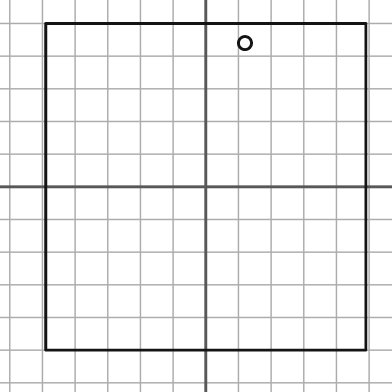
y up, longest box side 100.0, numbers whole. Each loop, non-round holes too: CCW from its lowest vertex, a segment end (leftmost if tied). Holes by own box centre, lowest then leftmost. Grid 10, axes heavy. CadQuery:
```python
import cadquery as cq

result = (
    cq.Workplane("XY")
    .moveTo(-49.0, -50.0)
    .lineTo(49.0, -50.0)
    .lineTo(49.0, 50.0)
    .lineTo(-49.0, 50.0)
    .close()
    .moveTo(12.0, 44.0)
    .circle(2.0)
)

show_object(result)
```